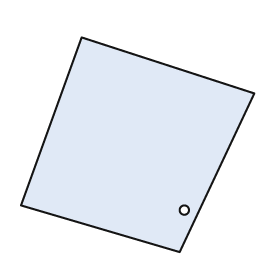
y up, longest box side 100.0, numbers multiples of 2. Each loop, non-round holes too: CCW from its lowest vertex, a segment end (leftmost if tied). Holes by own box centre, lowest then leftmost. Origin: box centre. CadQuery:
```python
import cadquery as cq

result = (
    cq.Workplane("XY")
    .moveTo(18.0, -46.0)
    .lineTo(50.0, 22.0)
    .lineTo(-24.0, 46.0)
    .lineTo(-50.0, -26.0)
    .close()
    .moveTo(20.0, -28.0)
    .circle(2.0)
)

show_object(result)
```